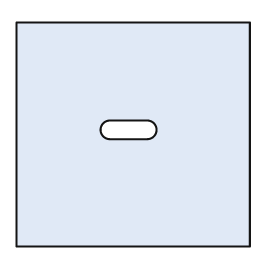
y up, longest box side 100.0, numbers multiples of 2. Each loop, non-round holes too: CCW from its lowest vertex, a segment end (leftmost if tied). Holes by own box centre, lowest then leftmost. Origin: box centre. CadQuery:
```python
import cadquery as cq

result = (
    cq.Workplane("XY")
    .moveTo(-50.0, -48.0)
    .lineTo(50.0, -48.0)
    .lineTo(50.0, 48.0)
    .lineTo(-50.0, 48.0)
    .close()
    .moveTo(-10.0, -2.0)
    .lineTo(6.0, -2.0)
    .threePointArc((10.0, 2.0), (6.0, 6.0))
    .lineTo(-10.0, 6.0)
    .threePointArc((-14.0, 2.0), (-10.0, -2.0))
    .close()
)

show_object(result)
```